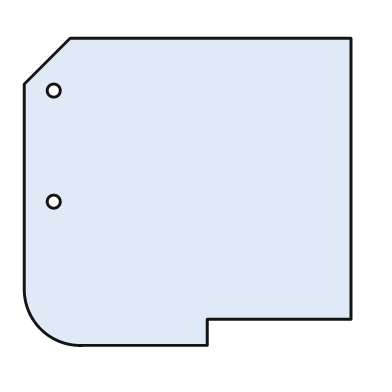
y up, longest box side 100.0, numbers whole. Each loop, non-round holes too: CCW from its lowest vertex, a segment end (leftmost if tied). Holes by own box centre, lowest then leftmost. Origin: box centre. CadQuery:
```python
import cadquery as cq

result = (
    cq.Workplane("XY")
    .moveTo(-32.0, -47.0)
    .lineTo(6.0, -47.0)
    .lineTo(6.0, -39.0)
    .lineTo(50.0, -39.0)
    .lineTo(50.0, 47.0)
    .lineTo(-36.0, 47.0)
    .lineTo(-50.0, 33.0)
    .lineTo(-50.0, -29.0)
    .threePointArc((-45.0, -42.0), (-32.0, -47.0))
    .close()
    .moveTo(-41.0, -3.0)
    .circle(2.0)
    .moveTo(-41.0, 31.0)
    .circle(2.0)
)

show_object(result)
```